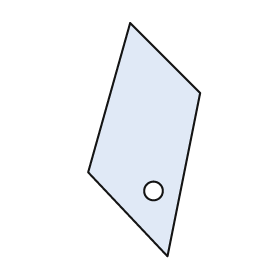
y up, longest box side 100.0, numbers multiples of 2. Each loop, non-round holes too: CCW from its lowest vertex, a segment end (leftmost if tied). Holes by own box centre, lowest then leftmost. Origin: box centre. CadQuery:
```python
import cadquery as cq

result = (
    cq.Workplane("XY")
    .moveTo(10.0, -50.0)
    .lineTo(24.0, 20.0)
    .lineTo(-6.0, 50.0)
    .lineTo(-24.0, -14.0)
    .close()
    .moveTo(4.0, -22.0)
    .circle(4.0)
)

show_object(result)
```